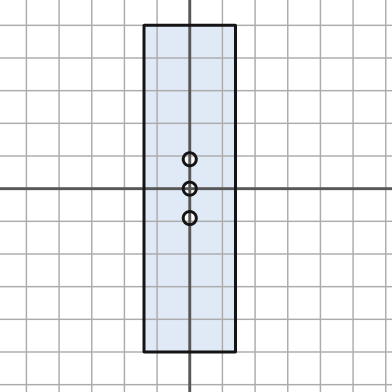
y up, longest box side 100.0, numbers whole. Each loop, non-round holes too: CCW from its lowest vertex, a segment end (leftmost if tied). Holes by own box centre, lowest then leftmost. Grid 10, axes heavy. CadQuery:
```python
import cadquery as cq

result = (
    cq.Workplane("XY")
    .moveTo(-14.0, -50.0)
    .lineTo(14.0, -50.0)
    .lineTo(14.0, 50.0)
    .lineTo(-14.0, 50.0)
    .close()
    .moveTo(0.0, -9.0)
    .circle(2.0)
    .moveTo(0.0, 0.0)
    .circle(2.0)
    .moveTo(0.0, 9.0)
    .circle(2.0)
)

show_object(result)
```